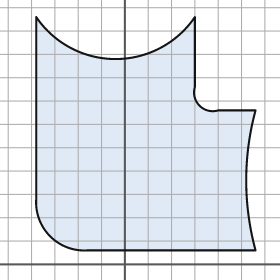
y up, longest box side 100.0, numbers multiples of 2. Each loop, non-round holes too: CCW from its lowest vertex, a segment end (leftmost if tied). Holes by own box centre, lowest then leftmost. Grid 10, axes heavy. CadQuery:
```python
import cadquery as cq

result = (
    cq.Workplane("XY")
    .moveTo(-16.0, 6.0)
    .lineTo(56.0, 6.0)
    .threePointArc((52.0, 36.0), (56.0, 66.0))
    .lineTo(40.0, 66.0)
    .threePointArc((32.0, 68.0), (30.0, 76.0))
    .lineTo(30.0, 106.0)
    .threePointArc((-4.0, 88.0), (-38.0, 106.0))
    .lineTo(-38.0, 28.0)
    .threePointArc((-32.0, 12.0), (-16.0, 6.0))
    .close()
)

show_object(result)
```